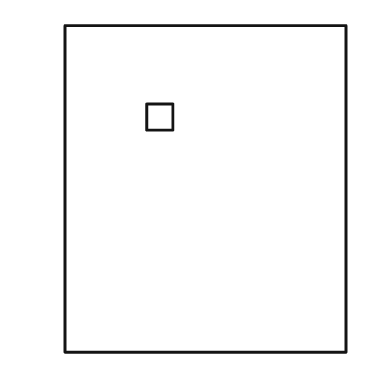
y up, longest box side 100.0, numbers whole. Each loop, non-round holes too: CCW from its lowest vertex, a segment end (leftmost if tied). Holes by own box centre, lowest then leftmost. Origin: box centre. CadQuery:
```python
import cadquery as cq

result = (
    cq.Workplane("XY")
    .moveTo(-43.0, -50.0)
    .lineTo(43.0, -50.0)
    .lineTo(43.0, 50.0)
    .lineTo(-43.0, 50.0)
    .close()
    .moveTo(-18.0, 18.0)
    .lineTo(-10.0, 18.0)
    .lineTo(-10.0, 26.0)
    .lineTo(-18.0, 26.0)
    .close()
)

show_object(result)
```